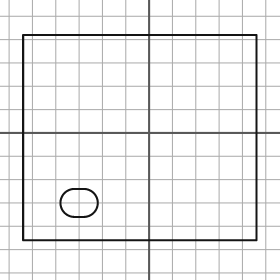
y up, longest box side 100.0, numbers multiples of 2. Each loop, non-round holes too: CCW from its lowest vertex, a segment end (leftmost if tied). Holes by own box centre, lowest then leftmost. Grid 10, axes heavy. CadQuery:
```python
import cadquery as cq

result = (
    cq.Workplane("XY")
    .moveTo(-54.0, -46.0)
    .lineTo(46.0, -46.0)
    .lineTo(46.0, 42.0)
    .lineTo(-54.0, 42.0)
    .close()
    .moveTo(-32.0, -36.0)
    .lineTo(-28.0, -36.0)
    .threePointArc((-22.0, -30.0), (-28.0, -24.0))
    .lineTo(-32.0, -24.0)
    .threePointArc((-38.0, -30.0), (-32.0, -36.0))
    .close()
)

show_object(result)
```